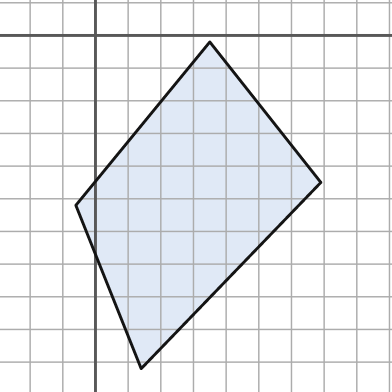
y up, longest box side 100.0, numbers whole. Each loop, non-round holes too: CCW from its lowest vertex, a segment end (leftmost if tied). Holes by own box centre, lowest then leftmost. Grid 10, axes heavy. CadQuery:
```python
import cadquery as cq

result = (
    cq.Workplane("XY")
    .moveTo(14.0, -102.0)
    .lineTo(69.0, -45.0)
    .lineTo(35.0, -2.0)
    .lineTo(-6.0, -52.0)
    .close()
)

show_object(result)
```